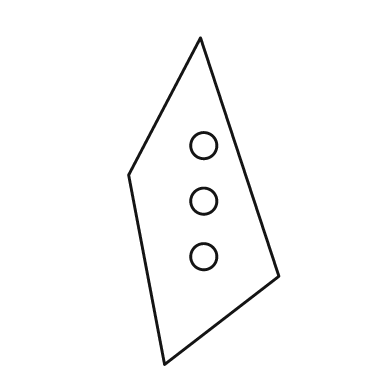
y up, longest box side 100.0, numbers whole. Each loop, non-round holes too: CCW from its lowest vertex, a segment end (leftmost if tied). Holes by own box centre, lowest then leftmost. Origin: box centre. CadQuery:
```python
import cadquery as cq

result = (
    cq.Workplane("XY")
    .moveTo(-12.0, -50.0)
    .lineTo(23.0, -23.0)
    .lineTo(-1.0, 50.0)
    .lineTo(-23.0, 8.0)
    .close()
    .moveTo(0.0, -17.0)
    .circle(4.0)
    .moveTo(0.0, 0.0)
    .circle(4.0)
    .moveTo(0.0, 17.0)
    .circle(4.0)
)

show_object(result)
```